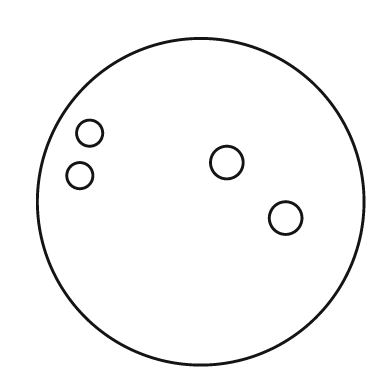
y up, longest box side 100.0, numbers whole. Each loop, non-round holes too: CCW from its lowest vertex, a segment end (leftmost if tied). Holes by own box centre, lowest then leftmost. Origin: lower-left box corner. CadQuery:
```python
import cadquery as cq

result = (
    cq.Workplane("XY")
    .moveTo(50.0, 50.0)
    .circle(50.0)
    .moveTo(76.0, 45.0)
    .circle(5.0)
    .moveTo(13.0, 58.0)
    .circle(4.0)
    .moveTo(58.0, 62.0)
    .circle(5.0)
    .moveTo(16.0, 71.0)
    .circle(4.0)
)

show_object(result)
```